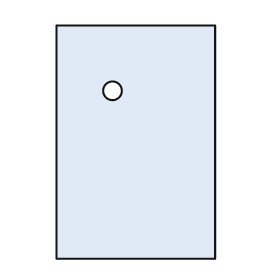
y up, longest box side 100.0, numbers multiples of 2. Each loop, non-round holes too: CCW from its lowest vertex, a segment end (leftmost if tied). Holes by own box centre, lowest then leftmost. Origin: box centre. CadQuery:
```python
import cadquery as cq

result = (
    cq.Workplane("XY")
    .moveTo(-34.0, -50.0)
    .lineTo(34.0, -50.0)
    .lineTo(34.0, 50.0)
    .lineTo(-34.0, 50.0)
    .close()
    .moveTo(-10.0, 22.0)
    .circle(4.0)
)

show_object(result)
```